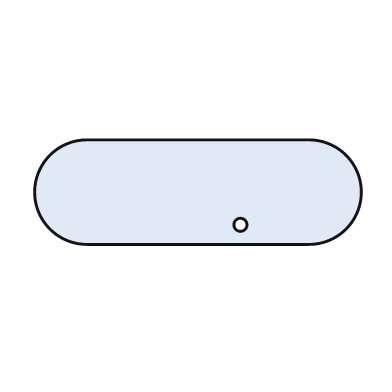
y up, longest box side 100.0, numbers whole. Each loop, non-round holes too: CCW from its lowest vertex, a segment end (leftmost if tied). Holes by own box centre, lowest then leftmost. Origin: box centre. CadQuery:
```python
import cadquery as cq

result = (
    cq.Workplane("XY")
    .moveTo(-34.0, -16.0)
    .lineTo(34.0, -16.0)
    .threePointArc((50.0, 0.0), (34.0, 16.0))
    .lineTo(-34.0, 16.0)
    .threePointArc((-50.0, 0.0), (-34.0, -16.0))
    .close()
    .moveTo(13.0, -10.0)
    .circle(2.0)
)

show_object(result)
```